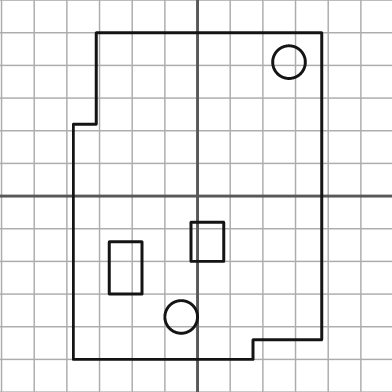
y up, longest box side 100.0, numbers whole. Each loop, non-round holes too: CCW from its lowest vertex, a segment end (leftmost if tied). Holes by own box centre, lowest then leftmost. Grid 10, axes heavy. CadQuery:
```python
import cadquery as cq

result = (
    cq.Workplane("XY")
    .moveTo(-38.0, -50.0)
    .lineTo(17.0, -50.0)
    .lineTo(17.0, -44.0)
    .lineTo(38.0, -44.0)
    .lineTo(38.0, 50.0)
    .lineTo(-31.0, 50.0)
    .lineTo(-31.0, 22.0)
    .lineTo(-38.0, 22.0)
    .close()
    .moveTo(-5.0, -37.0)
    .circle(5.0)
    .moveTo(-27.0, -30.0)
    .lineTo(-17.0, -30.0)
    .lineTo(-17.0, -14.0)
    .lineTo(-27.0, -14.0)
    .close()
    .moveTo(-2.0, -20.0)
    .lineTo(8.0, -20.0)
    .lineTo(8.0, -8.0)
    .lineTo(-2.0, -8.0)
    .close()
    .moveTo(28.0, 41.0)
    .circle(5.0)
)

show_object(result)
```